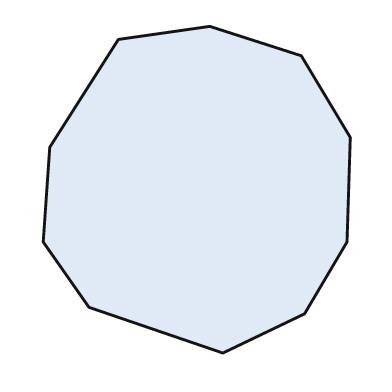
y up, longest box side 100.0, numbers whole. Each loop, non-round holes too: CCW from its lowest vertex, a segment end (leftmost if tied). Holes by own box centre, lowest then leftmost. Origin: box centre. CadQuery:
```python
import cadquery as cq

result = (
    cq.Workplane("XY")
    .moveTo(8.0, -50.0)
    .lineTo(33.0, -38.0)
    .lineTo(46.0, -16.0)
    .lineTo(47.0, 16.0)
    .lineTo(32.0, 41.0)
    .lineTo(4.0, 50.0)
    .lineTo(-24.0, 46.0)
    .lineTo(-45.0, 13.0)
    .lineTo(-47.0, -16.0)
    .lineTo(-33.0, -36.0)
    .close()
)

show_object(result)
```